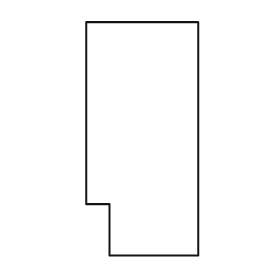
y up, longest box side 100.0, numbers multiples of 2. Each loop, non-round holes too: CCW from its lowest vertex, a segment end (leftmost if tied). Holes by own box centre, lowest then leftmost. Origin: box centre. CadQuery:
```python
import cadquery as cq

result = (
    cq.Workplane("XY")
    .moveTo(-14.0, -50.0)
    .lineTo(24.0, -50.0)
    .lineTo(24.0, 50.0)
    .lineTo(-24.0, 50.0)
    .lineTo(-24.0, -28.0)
    .lineTo(-14.0, -28.0)
    .close()
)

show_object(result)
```